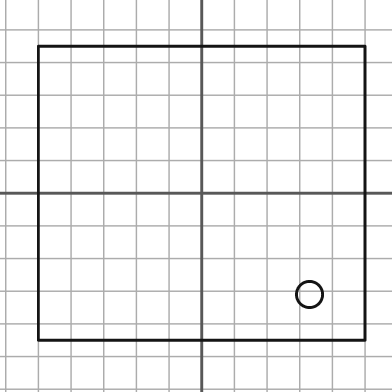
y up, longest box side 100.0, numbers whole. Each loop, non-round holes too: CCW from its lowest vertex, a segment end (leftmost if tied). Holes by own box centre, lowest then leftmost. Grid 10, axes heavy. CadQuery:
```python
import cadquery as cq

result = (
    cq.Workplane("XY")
    .moveTo(-50.0, -45.0)
    .lineTo(50.0, -45.0)
    .lineTo(50.0, 45.0)
    .lineTo(-50.0, 45.0)
    .close()
    .moveTo(33.0, -31.0)
    .circle(4.0)
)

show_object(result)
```